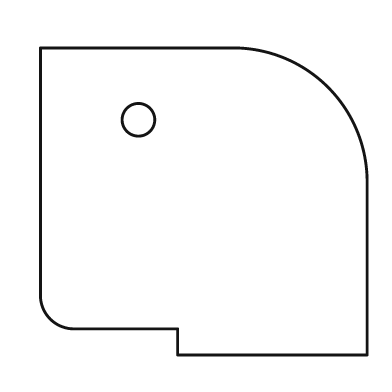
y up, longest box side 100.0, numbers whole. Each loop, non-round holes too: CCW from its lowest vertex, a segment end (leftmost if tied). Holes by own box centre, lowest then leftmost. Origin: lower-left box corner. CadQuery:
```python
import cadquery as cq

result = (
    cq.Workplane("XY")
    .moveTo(42.0, 0.0)
    .lineTo(100.0, 0.0)
    .lineTo(100.0, 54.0)
    .threePointArc((88.0, 82.0), (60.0, 94.0))
    .lineTo(0.0, 94.0)
    .lineTo(0.0, 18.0)
    .threePointArc((3.0, 11.0), (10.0, 8.0))
    .lineTo(42.0, 8.0)
    .close()
    .moveTo(30.0, 72.0)
    .circle(5.0)
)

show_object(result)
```